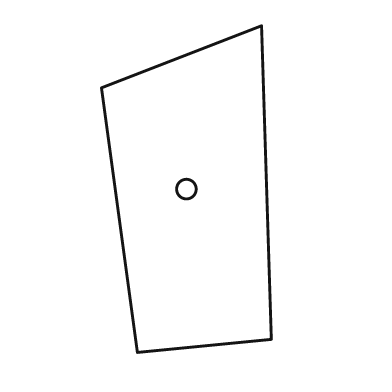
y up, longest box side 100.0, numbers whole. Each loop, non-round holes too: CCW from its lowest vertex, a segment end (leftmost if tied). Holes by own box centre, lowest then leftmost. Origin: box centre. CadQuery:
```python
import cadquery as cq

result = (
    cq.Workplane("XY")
    .moveTo(-15.0, -50.0)
    .lineTo(26.0, -46.0)
    .lineTo(23.0, 50.0)
    .lineTo(-26.0, 31.0)
    .close()
    .moveTo(0.0, 0.0)
    .circle(3.0)
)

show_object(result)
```